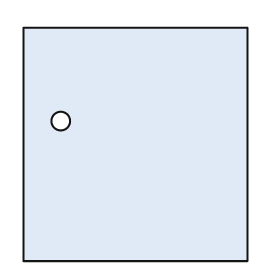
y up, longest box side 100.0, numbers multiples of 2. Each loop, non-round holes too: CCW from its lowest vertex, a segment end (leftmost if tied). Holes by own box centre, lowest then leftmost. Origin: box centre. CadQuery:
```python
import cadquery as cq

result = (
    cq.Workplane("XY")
    .moveTo(-48.0, -50.0)
    .lineTo(48.0, -50.0)
    .lineTo(48.0, 50.0)
    .lineTo(-48.0, 50.0)
    .close()
    .moveTo(-32.0, 10.0)
    .circle(4.0)
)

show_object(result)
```